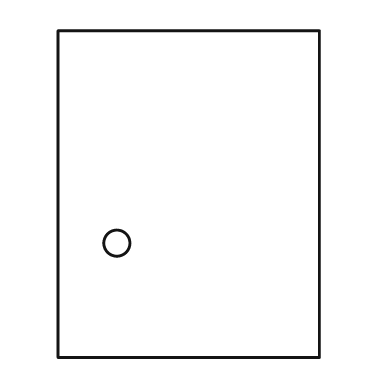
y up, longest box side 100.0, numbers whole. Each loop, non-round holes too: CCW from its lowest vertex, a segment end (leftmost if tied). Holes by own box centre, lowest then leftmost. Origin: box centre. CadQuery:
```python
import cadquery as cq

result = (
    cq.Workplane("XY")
    .moveTo(-40.0, -50.0)
    .lineTo(40.0, -50.0)
    .lineTo(40.0, 50.0)
    .lineTo(-40.0, 50.0)
    .close()
    .moveTo(-22.0, -15.0)
    .circle(4.0)
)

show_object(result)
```